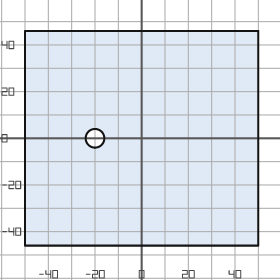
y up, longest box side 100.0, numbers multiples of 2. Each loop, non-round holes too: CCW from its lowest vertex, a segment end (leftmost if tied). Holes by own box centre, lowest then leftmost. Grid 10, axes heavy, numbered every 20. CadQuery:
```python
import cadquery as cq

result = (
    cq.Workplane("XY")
    .moveTo(-50.0, -46.0)
    .lineTo(50.0, -46.0)
    .lineTo(50.0, 46.0)
    .lineTo(-50.0, 46.0)
    .close()
    .moveTo(-20.0, 0.0)
    .circle(4.0)
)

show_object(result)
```